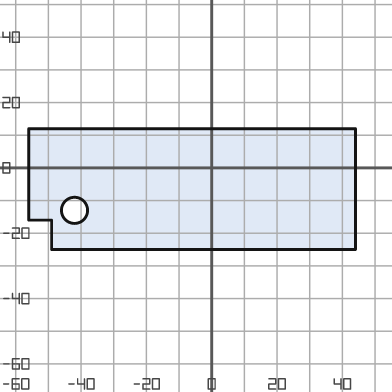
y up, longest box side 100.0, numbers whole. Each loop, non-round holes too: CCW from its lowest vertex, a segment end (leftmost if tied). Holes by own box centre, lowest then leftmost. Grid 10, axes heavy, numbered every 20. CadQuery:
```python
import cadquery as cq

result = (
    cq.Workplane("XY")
    .moveTo(-49.0, -25.0)
    .lineTo(44.0, -25.0)
    .lineTo(44.0, 12.0)
    .lineTo(-56.0, 12.0)
    .lineTo(-56.0, -16.0)
    .lineTo(-49.0, -16.0)
    .close()
    .moveTo(-42.0, -13.0)
    .circle(4.0)
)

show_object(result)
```